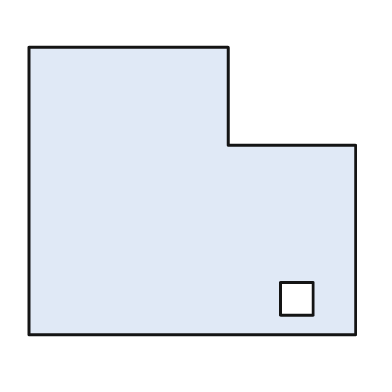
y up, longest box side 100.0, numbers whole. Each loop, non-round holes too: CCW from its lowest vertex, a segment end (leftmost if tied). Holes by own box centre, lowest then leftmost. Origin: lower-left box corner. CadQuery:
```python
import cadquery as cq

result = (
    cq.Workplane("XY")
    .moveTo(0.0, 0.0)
    .lineTo(100.0, 0.0)
    .lineTo(100.0, 58.0)
    .lineTo(61.0, 58.0)
    .lineTo(61.0, 88.0)
    .lineTo(0.0, 88.0)
    .close()
    .moveTo(77.0, 6.0)
    .lineTo(87.0, 6.0)
    .lineTo(87.0, 16.0)
    .lineTo(77.0, 16.0)
    .close()
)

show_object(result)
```